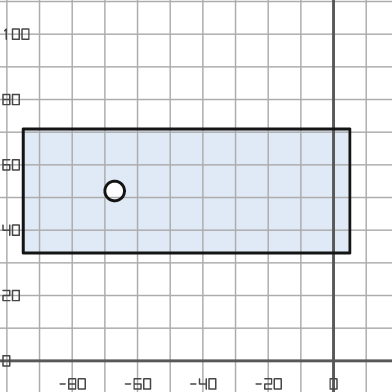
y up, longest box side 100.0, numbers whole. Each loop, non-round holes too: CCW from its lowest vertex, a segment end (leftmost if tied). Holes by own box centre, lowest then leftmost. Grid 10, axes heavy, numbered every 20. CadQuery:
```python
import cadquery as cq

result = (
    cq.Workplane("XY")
    .moveTo(-95.0, 33.0)
    .lineTo(5.0, 33.0)
    .lineTo(5.0, 71.0)
    .lineTo(-95.0, 71.0)
    .close()
    .moveTo(-67.0, 52.0)
    .circle(3.0)
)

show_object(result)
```